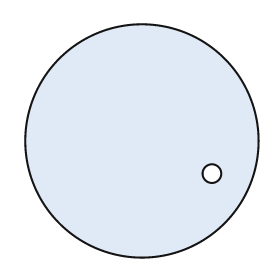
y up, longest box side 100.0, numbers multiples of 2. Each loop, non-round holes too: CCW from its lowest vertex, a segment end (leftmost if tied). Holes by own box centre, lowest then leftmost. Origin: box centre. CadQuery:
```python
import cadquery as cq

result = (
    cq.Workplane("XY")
    .moveTo(0.0, 0.0)
    .circle(50.0)
    .moveTo(30.0, -14.0)
    .circle(4.0)
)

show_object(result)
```